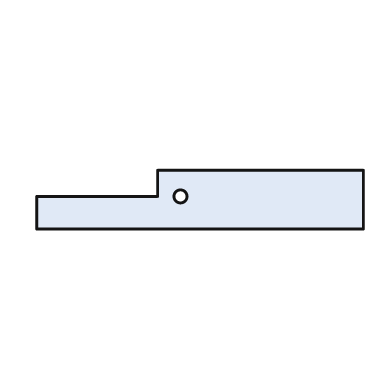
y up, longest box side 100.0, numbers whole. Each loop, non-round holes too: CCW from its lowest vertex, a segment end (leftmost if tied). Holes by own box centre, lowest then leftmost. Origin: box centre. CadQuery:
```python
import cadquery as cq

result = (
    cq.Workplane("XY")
    .moveTo(-50.0, -9.0)
    .lineTo(50.0, -9.0)
    .lineTo(50.0, 9.0)
    .lineTo(-13.0, 9.0)
    .lineTo(-13.0, 1.0)
    .lineTo(-50.0, 1.0)
    .close()
    .moveTo(-6.0, 1.0)
    .circle(2.0)
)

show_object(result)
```